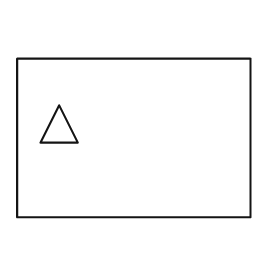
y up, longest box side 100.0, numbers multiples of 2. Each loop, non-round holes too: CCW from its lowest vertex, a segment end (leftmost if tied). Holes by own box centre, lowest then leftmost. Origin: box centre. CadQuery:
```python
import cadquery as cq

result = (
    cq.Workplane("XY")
    .moveTo(-50.0, -34.0)
    .lineTo(50.0, -34.0)
    .lineTo(50.0, 34.0)
    .lineTo(-50.0, 34.0)
    .close()
    .moveTo(-40.0, -2.0)
    .lineTo(-24.0, -2.0)
    .lineTo(-32.0, 14.0)
    .close()
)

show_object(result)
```